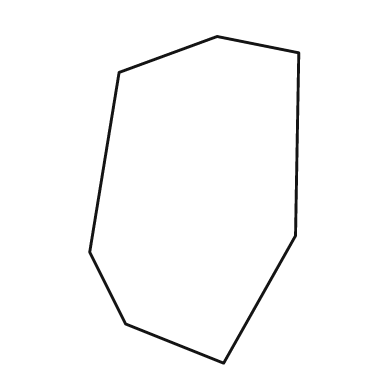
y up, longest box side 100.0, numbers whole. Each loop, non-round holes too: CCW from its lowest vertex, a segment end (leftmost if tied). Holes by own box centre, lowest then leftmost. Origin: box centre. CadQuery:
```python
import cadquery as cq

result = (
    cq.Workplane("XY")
    .moveTo(9.0, -50.0)
    .lineTo(31.0, -11.0)
    .lineTo(32.0, 45.0)
    .lineTo(7.0, 50.0)
    .lineTo(-23.0, 39.0)
    .lineTo(-32.0, -16.0)
    .lineTo(-21.0, -38.0)
    .close()
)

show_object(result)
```